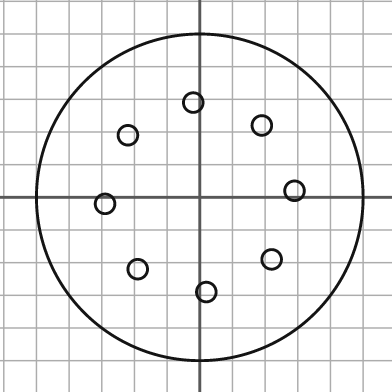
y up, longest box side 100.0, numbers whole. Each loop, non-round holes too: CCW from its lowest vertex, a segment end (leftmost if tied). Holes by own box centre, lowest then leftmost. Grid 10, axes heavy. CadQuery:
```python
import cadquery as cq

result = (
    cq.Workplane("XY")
    .moveTo(0.0, 0.0)
    .circle(50.0)
    .moveTo(2.0, -29.0)
    .circle(3.0)
    .moveTo(-19.0, -22.0)
    .circle(3.0)
    .moveTo(22.0, -19.0)
    .circle(3.0)
    .moveTo(-29.0, -2.0)
    .circle(3.0)
    .moveTo(29.0, 2.0)
    .circle(3.0)
    .moveTo(-22.0, 19.0)
    .circle(3.0)
    .moveTo(19.0, 22.0)
    .circle(3.0)
    .moveTo(-2.0, 29.0)
    .circle(3.0)
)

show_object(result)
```